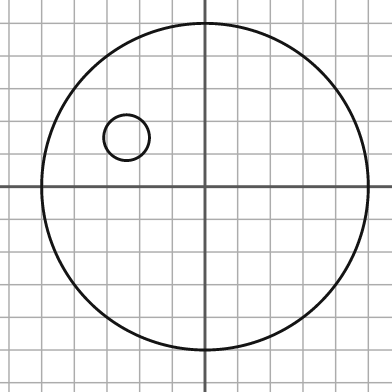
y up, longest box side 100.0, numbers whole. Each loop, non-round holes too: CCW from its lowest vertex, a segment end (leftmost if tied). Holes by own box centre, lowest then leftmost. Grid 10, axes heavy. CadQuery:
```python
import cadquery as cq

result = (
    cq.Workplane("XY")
    .moveTo(0.0, 0.0)
    .circle(50.0)
    .moveTo(-24.0, 15.0)
    .circle(7.0)
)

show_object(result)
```